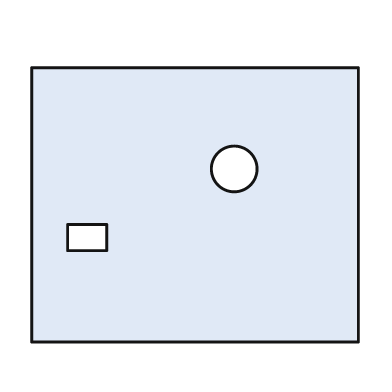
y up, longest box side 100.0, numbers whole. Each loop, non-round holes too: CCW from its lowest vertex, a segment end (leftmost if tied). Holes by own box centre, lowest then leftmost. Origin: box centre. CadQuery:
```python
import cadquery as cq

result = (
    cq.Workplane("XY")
    .moveTo(-50.0, -42.0)
    .lineTo(50.0, -42.0)
    .lineTo(50.0, 42.0)
    .lineTo(-50.0, 42.0)
    .close()
    .moveTo(-39.0, -14.0)
    .lineTo(-27.0, -14.0)
    .lineTo(-27.0, -6.0)
    .lineTo(-39.0, -6.0)
    .close()
    .moveTo(12.0, 11.0)
    .circle(7.0)
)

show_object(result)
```